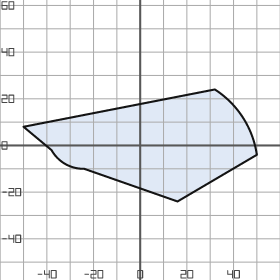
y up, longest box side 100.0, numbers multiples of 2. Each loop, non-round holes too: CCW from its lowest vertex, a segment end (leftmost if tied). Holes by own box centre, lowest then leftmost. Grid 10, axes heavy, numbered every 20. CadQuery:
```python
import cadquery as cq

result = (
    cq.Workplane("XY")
    .moveTo(16.0, -24.0)
    .lineTo(50.0, -4.0)
    .threePointArc((44.0, 12.0), (32.0, 24.0))
    .lineTo(-50.0, 8.0)
    .lineTo(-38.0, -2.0)
    .threePointArc((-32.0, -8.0), (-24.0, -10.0))
    .close()
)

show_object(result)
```